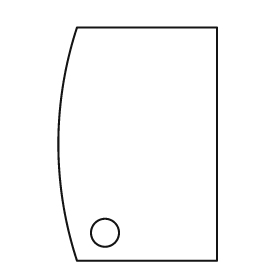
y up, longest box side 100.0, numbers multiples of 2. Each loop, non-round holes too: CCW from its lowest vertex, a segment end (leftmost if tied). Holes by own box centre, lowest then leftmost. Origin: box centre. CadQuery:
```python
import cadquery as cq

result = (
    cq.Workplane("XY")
    .moveTo(-26.0, -50.0)
    .lineTo(34.0, -50.0)
    .lineTo(34.0, 50.0)
    .lineTo(-26.0, 50.0)
    .threePointArc((-34.0, 0.0), (-26.0, -50.0))
    .close()
    .moveTo(-14.0, -38.0)
    .circle(6.0)
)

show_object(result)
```